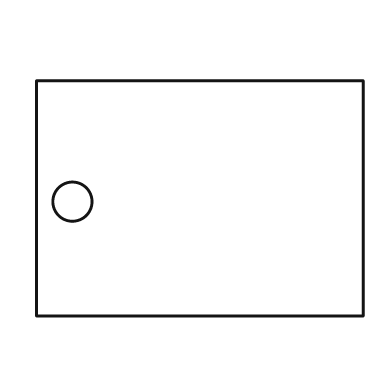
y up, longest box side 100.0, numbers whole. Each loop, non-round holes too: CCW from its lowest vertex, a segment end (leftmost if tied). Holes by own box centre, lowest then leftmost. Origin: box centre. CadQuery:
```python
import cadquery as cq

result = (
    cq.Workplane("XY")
    .moveTo(-50.0, -36.0)
    .lineTo(50.0, -36.0)
    .lineTo(50.0, 36.0)
    .lineTo(-50.0, 36.0)
    .close()
    .moveTo(-39.0, -1.0)
    .circle(6.0)
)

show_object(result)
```